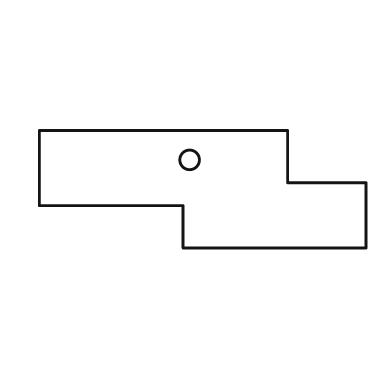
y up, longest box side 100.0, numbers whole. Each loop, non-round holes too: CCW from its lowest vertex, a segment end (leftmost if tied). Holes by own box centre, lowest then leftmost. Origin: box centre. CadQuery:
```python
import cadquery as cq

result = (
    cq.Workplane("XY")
    .moveTo(-6.0, -18.0)
    .lineTo(50.0, -18.0)
    .lineTo(50.0, 2.0)
    .lineTo(26.0, 2.0)
    .lineTo(26.0, 18.0)
    .lineTo(-50.0, 18.0)
    .lineTo(-50.0, -5.0)
    .lineTo(-6.0, -5.0)
    .close()
    .moveTo(-4.0, 9.0)
    .circle(3.0)
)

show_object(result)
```